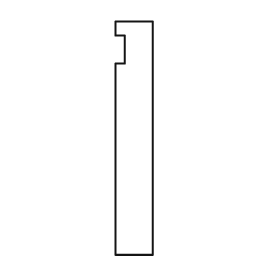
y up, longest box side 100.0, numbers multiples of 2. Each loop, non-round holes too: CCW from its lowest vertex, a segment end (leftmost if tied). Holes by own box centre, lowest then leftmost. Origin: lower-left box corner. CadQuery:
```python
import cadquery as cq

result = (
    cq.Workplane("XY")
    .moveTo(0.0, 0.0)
    .lineTo(16.0, 0.0)
    .lineTo(16.0, 100.0)
    .lineTo(0.0, 100.0)
    .lineTo(0.0, 94.0)
    .lineTo(4.0, 94.0)
    .lineTo(4.0, 82.0)
    .lineTo(0.0, 82.0)
    .close()
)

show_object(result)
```